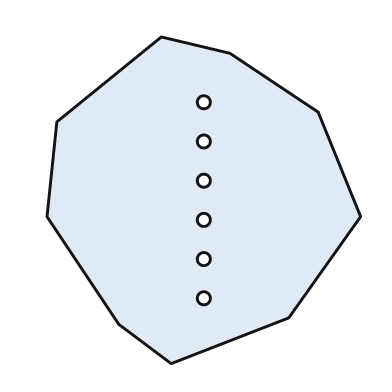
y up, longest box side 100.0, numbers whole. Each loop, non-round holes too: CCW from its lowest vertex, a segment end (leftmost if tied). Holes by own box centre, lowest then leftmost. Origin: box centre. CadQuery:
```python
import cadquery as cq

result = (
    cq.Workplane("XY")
    .moveTo(-10.0, -50.0)
    .lineTo(26.0, -36.0)
    .lineTo(48.0, -5.0)
    .lineTo(35.0, 27.0)
    .lineTo(8.0, 45.0)
    .lineTo(-13.0, 50.0)
    .lineTo(-45.0, 24.0)
    .lineTo(-48.0, -5.0)
    .lineTo(-26.0, -38.0)
    .close()
    .moveTo(0.0, -30.0)
    .circle(2.0)
    .moveTo(0.0, -18.0)
    .circle(2.0)
    .moveTo(0.0, -6.0)
    .circle(2.0)
    .moveTo(0.0, 6.0)
    .circle(2.0)
    .moveTo(0.0, 18.0)
    .circle(2.0)
    .moveTo(0.0, 30.0)
    .circle(2.0)
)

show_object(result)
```